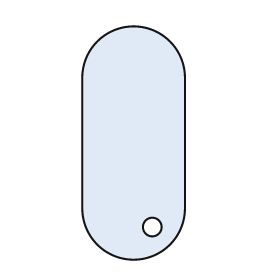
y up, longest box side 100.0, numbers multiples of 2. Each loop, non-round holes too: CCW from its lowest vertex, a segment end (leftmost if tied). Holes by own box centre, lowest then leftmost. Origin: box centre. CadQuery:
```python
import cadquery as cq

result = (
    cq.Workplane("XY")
    .moveTo(-22.0, -28.0)
    .threePointArc((0.0, -50.0), (22.0, -28.0))
    .lineTo(22.0, 28.0)
    .threePointArc((0.0, 50.0), (-22.0, 28.0))
    .close()
    .moveTo(8.0, -36.0)
    .circle(4.0)
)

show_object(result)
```